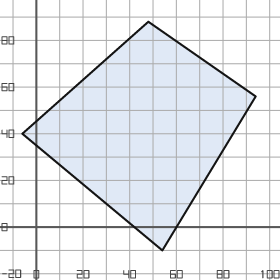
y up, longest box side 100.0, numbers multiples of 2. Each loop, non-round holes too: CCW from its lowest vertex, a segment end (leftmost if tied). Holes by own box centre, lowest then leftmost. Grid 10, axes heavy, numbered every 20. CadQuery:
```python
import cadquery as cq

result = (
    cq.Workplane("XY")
    .moveTo(54.0, -10.0)
    .lineTo(94.0, 56.0)
    .lineTo(48.0, 88.0)
    .lineTo(-6.0, 40.0)
    .close()
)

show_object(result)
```